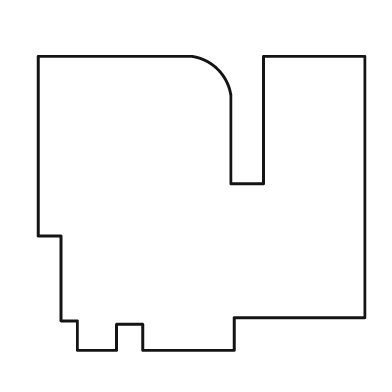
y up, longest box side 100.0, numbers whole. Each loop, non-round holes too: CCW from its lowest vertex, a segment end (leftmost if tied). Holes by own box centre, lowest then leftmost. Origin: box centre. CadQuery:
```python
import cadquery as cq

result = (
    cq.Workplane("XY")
    .moveTo(-38.0, -45.0)
    .lineTo(-26.0, -45.0)
    .lineTo(-26.0, -37.0)
    .lineTo(-18.0, -37.0)
    .lineTo(-18.0, -45.0)
    .lineTo(10.0, -45.0)
    .lineTo(10.0, -35.0)
    .lineTo(50.0, -35.0)
    .lineTo(50.0, 45.0)
    .lineTo(19.0, 45.0)
    .lineTo(19.0, 6.0)
    .lineTo(9.0, 6.0)
    .lineTo(9.0, 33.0)
    .threePointArc((5.0, 41.0), (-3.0, 45.0))
    .lineTo(-50.0, 45.0)
    .lineTo(-50.0, -10.0)
    .lineTo(-43.0, -10.0)
    .lineTo(-43.0, -36.0)
    .lineTo(-38.0, -36.0)
    .close()
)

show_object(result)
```